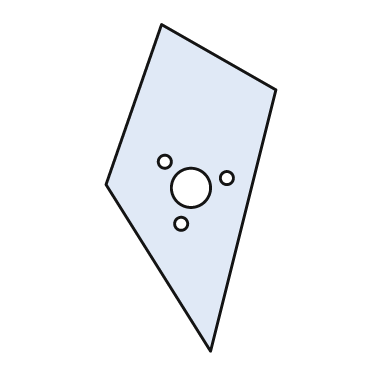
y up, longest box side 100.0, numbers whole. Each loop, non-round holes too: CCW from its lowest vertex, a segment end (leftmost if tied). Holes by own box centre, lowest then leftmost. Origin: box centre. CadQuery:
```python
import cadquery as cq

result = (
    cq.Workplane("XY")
    .moveTo(6.0, -50.0)
    .lineTo(26.0, 30.0)
    .lineTo(-9.0, 50.0)
    .lineTo(-26.0, 1.0)
    .close()
    .moveTo(-3.0, -11.0)
    .circle(2.0)
    .moveTo(0.0, 0.0)
    .circle(6.0)
    .moveTo(11.0, 3.0)
    .circle(2.0)
    .moveTo(-8.0, 8.0)
    .circle(2.0)
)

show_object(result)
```